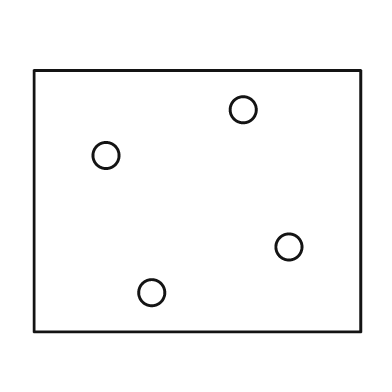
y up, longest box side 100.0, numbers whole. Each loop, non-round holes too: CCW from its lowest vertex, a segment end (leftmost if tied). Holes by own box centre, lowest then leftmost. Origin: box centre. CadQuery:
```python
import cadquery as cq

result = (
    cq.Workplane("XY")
    .moveTo(-50.0, -40.0)
    .lineTo(50.0, -40.0)
    .lineTo(50.0, 40.0)
    .lineTo(-50.0, 40.0)
    .close()
    .moveTo(-14.0, -28.0)
    .circle(4.0)
    .moveTo(28.0, -14.0)
    .circle(4.0)
    .moveTo(-28.0, 14.0)
    .circle(4.0)
    .moveTo(14.0, 28.0)
    .circle(4.0)
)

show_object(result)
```